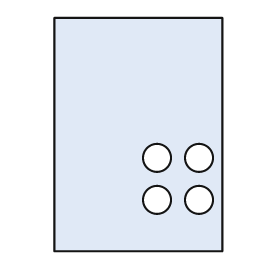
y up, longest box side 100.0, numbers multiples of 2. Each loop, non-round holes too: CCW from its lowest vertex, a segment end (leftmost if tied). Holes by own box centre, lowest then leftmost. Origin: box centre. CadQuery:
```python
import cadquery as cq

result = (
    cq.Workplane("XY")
    .moveTo(-36.0, -50.0)
    .lineTo(36.0, -50.0)
    .lineTo(36.0, 50.0)
    .lineTo(-36.0, 50.0)
    .close()
    .moveTo(8.0, -28.0)
    .circle(6.0)
    .moveTo(26.0, -28.0)
    .circle(6.0)
    .moveTo(8.0, -10.0)
    .circle(6.0)
    .moveTo(26.0, -10.0)
    .circle(6.0)
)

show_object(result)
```